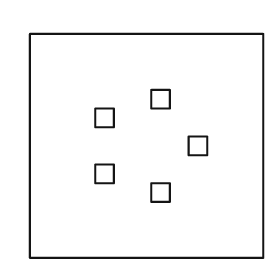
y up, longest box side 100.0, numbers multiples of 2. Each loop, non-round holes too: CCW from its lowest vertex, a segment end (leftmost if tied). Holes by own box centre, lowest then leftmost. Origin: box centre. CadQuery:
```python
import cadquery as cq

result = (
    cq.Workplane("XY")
    .moveTo(-50.0, -48.0)
    .lineTo(50.0, -48.0)
    .lineTo(50.0, 48.0)
    .lineTo(-50.0, 48.0)
    .close()
    .moveTo(2.0, -24.0)
    .lineTo(10.0, -24.0)
    .lineTo(10.0, -16.0)
    .lineTo(2.0, -16.0)
    .close()
    .moveTo(-22.0, -16.0)
    .lineTo(-14.0, -16.0)
    .lineTo(-14.0, -8.0)
    .lineTo(-22.0, -8.0)
    .close()
    .moveTo(18.0, -4.0)
    .lineTo(26.0, -4.0)
    .lineTo(26.0, 4.0)
    .lineTo(18.0, 4.0)
    .close()
    .moveTo(-22.0, 8.0)
    .lineTo(-14.0, 8.0)
    .lineTo(-14.0, 16.0)
    .lineTo(-22.0, 16.0)
    .close()
    .moveTo(2.0, 16.0)
    .lineTo(10.0, 16.0)
    .lineTo(10.0, 24.0)
    .lineTo(2.0, 24.0)
    .close()
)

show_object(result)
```